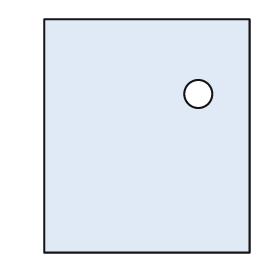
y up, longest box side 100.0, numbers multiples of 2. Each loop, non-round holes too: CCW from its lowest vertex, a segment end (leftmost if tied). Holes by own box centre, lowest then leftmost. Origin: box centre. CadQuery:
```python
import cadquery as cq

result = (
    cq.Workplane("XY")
    .moveTo(-44.0, -50.0)
    .lineTo(44.0, -50.0)
    .lineTo(44.0, 50.0)
    .lineTo(-44.0, 50.0)
    .close()
    .moveTo(22.0, 18.0)
    .circle(6.0)
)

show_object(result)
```